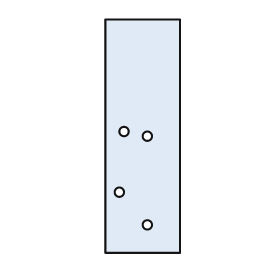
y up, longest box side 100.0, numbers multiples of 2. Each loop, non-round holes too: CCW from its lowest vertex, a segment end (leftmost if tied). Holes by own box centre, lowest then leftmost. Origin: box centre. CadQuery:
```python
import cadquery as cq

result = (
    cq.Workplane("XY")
    .moveTo(-16.0, -50.0)
    .lineTo(16.0, -50.0)
    .lineTo(16.0, 50.0)
    .lineTo(-16.0, 50.0)
    .close()
    .moveTo(2.0, -38.0)
    .circle(2.0)
    .moveTo(-10.0, -24.0)
    .circle(2.0)
    .moveTo(2.0, 0.0)
    .circle(2.0)
    .moveTo(-8.0, 2.0)
    .circle(2.0)
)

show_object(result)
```